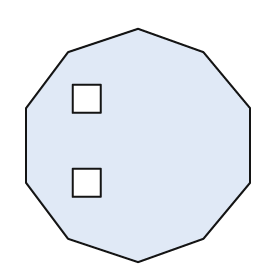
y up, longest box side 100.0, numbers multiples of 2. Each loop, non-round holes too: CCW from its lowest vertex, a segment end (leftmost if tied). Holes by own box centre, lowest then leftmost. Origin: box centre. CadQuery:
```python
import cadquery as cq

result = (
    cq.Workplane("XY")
    .moveTo(0.0, -50.0)
    .lineTo(28.0, -40.0)
    .lineTo(48.0, -16.0)
    .lineTo(48.0, 16.0)
    .lineTo(28.0, 40.0)
    .lineTo(0.0, 50.0)
    .lineTo(-30.0, 40.0)
    .lineTo(-48.0, 16.0)
    .lineTo(-48.0, -16.0)
    .lineTo(-30.0, -40.0)
    .close()
    .moveTo(-28.0, -22.0)
    .lineTo(-16.0, -22.0)
    .lineTo(-16.0, -10.0)
    .lineTo(-28.0, -10.0)
    .close()
    .moveTo(-28.0, 14.0)
    .lineTo(-16.0, 14.0)
    .lineTo(-16.0, 26.0)
    .lineTo(-28.0, 26.0)
    .close()
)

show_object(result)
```